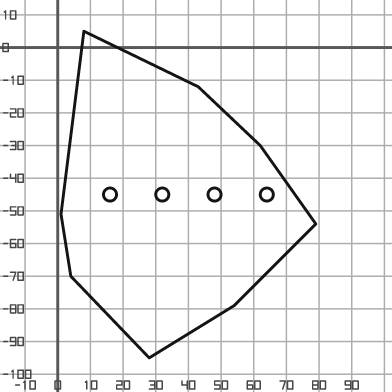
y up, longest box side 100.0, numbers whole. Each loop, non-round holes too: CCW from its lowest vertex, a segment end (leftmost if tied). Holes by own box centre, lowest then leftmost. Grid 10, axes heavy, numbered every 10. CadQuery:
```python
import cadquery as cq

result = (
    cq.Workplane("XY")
    .moveTo(28.0, -95.0)
    .lineTo(54.0, -79.0)
    .lineTo(79.0, -54.0)
    .lineTo(62.0, -30.0)
    .lineTo(43.0, -12.0)
    .lineTo(8.0, 5.0)
    .lineTo(1.0, -51.0)
    .lineTo(4.0, -70.0)
    .close()
    .moveTo(16.0, -45.0)
    .circle(2.0)
    .moveTo(32.0, -45.0)
    .circle(2.0)
    .moveTo(48.0, -45.0)
    .circle(2.0)
    .moveTo(64.0, -45.0)
    .circle(2.0)
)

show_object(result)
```